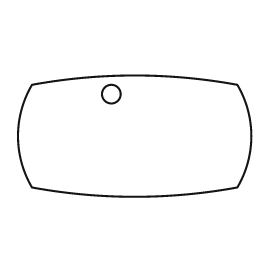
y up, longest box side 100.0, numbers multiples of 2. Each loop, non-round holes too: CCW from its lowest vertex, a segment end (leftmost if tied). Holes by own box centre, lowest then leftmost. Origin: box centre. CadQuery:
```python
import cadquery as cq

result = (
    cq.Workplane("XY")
    .moveTo(-44.0, -22.0)
    .threePointArc((0.0, -26.0), (44.0, -22.0))
    .threePointArc((50.0, 0.0), (44.0, 22.0))
    .threePointArc((0.0, 26.0), (-44.0, 22.0))
    .threePointArc((-50.0, 0.0), (-44.0, -22.0))
    .close()
    .moveTo(-10.0, 18.0)
    .circle(4.0)
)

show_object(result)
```